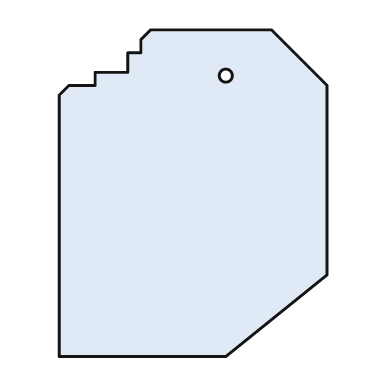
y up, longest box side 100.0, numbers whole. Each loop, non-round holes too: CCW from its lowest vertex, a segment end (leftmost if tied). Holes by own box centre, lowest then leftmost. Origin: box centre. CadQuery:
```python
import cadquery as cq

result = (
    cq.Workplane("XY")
    .moveTo(-41.0, -50.0)
    .lineTo(10.0, -50.0)
    .lineTo(41.0, -25.0)
    .lineTo(41.0, 33.0)
    .lineTo(24.0, 50.0)
    .lineTo(-13.0, 50.0)
    .lineTo(-16.0, 47.0)
    .lineTo(-16.0, 43.0)
    .lineTo(-20.0, 43.0)
    .lineTo(-20.0, 37.0)
    .lineTo(-30.0, 37.0)
    .lineTo(-30.0, 33.0)
    .lineTo(-38.0, 33.0)
    .lineTo(-41.0, 30.0)
    .close()
    .moveTo(10.0, 36.0)
    .circle(2.0)
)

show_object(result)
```